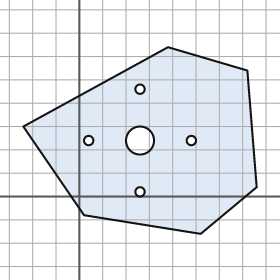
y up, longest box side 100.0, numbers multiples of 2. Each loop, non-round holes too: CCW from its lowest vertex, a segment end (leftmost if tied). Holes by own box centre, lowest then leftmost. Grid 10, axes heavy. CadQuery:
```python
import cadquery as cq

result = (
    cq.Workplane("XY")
    .moveTo(52.0, -16.0)
    .lineTo(76.0, 4.0)
    .lineTo(72.0, 54.0)
    .lineTo(38.0, 64.0)
    .lineTo(-24.0, 30.0)
    .lineTo(2.0, -8.0)
    .close()
    .moveTo(26.0, 2.0)
    .circle(2.0)
    .moveTo(4.0, 24.0)
    .circle(2.0)
    .moveTo(26.0, 24.0)
    .circle(6.0)
    .moveTo(48.0, 24.0)
    .circle(2.0)
    .moveTo(26.0, 46.0)
    .circle(2.0)
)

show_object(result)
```